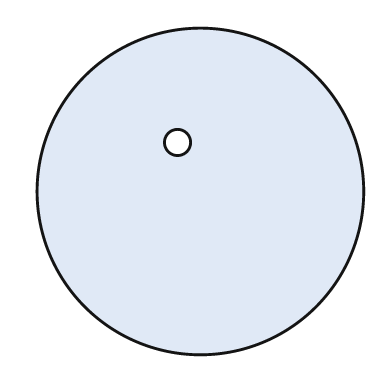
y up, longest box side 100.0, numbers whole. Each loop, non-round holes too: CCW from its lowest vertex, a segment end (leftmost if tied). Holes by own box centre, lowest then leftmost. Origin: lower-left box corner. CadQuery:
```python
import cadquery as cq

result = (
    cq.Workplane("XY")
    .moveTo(50.0, 50.0)
    .circle(50.0)
    .moveTo(43.0, 65.0)
    .circle(4.0)
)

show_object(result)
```